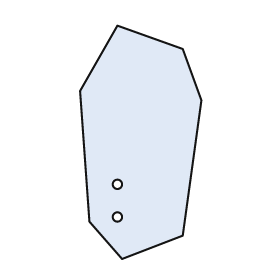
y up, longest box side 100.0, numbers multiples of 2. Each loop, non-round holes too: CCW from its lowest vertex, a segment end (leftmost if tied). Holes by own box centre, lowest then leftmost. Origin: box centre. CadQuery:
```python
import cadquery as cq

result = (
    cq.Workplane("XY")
    .moveTo(-8.0, -50.0)
    .lineTo(18.0, -40.0)
    .lineTo(26.0, 18.0)
    .lineTo(18.0, 40.0)
    .lineTo(-10.0, 50.0)
    .lineTo(-26.0, 22.0)
    .lineTo(-22.0, -34.0)
    .close()
    .moveTo(-10.0, -32.0)
    .circle(2.0)
    .moveTo(-10.0, -18.0)
    .circle(2.0)
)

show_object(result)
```